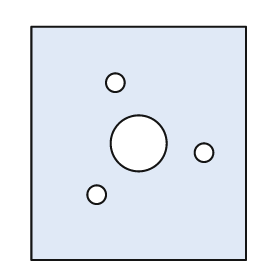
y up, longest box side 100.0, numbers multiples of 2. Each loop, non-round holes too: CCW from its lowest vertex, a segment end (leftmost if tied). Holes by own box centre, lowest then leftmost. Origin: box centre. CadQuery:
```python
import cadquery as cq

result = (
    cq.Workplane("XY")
    .moveTo(-46.0, -50.0)
    .lineTo(46.0, -50.0)
    .lineTo(46.0, 50.0)
    .lineTo(-46.0, 50.0)
    .close()
    .moveTo(-18.0, -22.0)
    .circle(4.0)
    .moveTo(28.0, -4.0)
    .circle(4.0)
    .moveTo(0.0, 0.0)
    .circle(12.0)
    .moveTo(-10.0, 26.0)
    .circle(4.0)
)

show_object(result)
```